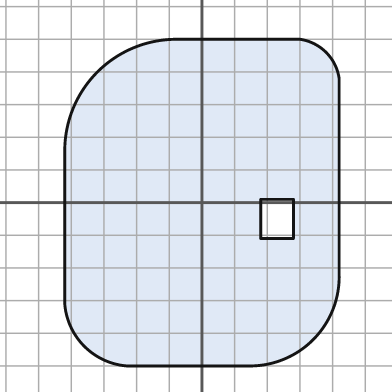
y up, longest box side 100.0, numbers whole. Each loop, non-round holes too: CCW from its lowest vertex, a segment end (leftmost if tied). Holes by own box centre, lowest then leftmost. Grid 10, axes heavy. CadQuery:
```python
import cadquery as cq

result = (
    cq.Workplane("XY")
    .moveTo(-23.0, -50.0)
    .lineTo(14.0, -50.0)
    .threePointArc((34.0, -42.0), (42.0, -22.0))
    .lineTo(42.0, 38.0)
    .threePointArc((38.0, 46.0), (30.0, 50.0))
    .lineTo(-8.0, 50.0)
    .threePointArc((-32.0, 40.0), (-42.0, 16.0))
    .lineTo(-42.0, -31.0)
    .threePointArc((-36.0, -44.0), (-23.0, -50.0))
    .close()
    .moveTo(18.0, -11.0)
    .lineTo(28.0, -11.0)
    .lineTo(28.0, 1.0)
    .lineTo(18.0, 1.0)
    .close()
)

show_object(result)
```